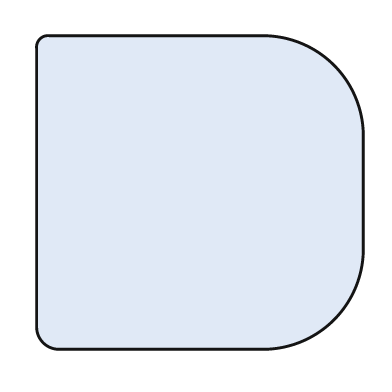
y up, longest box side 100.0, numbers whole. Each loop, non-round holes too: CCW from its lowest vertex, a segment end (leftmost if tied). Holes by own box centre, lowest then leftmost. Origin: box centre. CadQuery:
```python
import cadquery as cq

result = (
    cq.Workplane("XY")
    .moveTo(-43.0, -48.0)
    .lineTo(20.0, -48.0)
    .threePointArc((41.0, -39.0), (50.0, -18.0))
    .lineTo(50.0, 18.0)
    .threePointArc((41.0, 39.0), (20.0, 48.0))
    .lineTo(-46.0, 48.0)
    .threePointArc((-49.0, 47.0), (-50.0, 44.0))
    .lineTo(-50.0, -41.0)
    .threePointArc((-48.0, -46.0), (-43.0, -48.0))
    .close()
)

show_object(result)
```